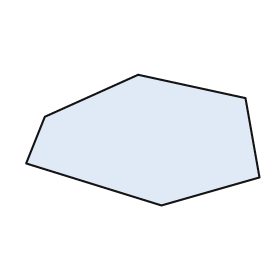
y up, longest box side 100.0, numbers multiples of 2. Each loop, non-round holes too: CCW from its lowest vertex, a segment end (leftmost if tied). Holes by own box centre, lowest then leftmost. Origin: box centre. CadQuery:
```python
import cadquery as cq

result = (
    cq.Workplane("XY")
    .moveTo(8.0, -28.0)
    .lineTo(50.0, -16.0)
    .lineTo(44.0, 18.0)
    .lineTo(-2.0, 28.0)
    .lineTo(-42.0, 10.0)
    .lineTo(-50.0, -10.0)
    .close()
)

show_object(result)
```